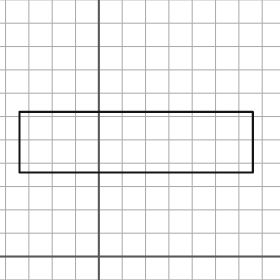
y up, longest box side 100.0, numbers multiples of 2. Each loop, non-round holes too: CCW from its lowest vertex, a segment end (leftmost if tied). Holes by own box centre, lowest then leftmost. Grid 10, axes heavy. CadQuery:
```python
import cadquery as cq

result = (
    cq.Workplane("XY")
    .moveTo(-34.0, 36.0)
    .lineTo(66.0, 36.0)
    .lineTo(66.0, 62.0)
    .lineTo(-34.0, 62.0)
    .close()
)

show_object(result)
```